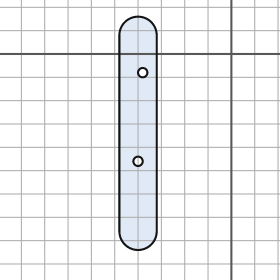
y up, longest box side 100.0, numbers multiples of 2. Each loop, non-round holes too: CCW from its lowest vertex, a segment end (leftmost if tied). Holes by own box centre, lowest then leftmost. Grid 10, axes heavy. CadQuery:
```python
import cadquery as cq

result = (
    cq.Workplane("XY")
    .moveTo(-48.0, -76.0)
    .threePointArc((-40.0, -84.0), (-32.0, -76.0))
    .lineTo(-32.0, 8.0)
    .threePointArc((-40.0, 16.0), (-48.0, 8.0))
    .close()
    .moveTo(-40.0, -46.0)
    .circle(2.0)
    .moveTo(-38.0, -8.0)
    .circle(2.0)
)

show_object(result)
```